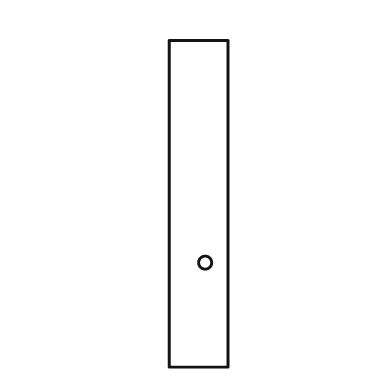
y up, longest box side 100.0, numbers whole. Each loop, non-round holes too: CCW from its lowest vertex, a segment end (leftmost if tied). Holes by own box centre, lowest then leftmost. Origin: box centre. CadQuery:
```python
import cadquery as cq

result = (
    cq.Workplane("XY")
    .moveTo(-9.0, -50.0)
    .lineTo(9.0, -50.0)
    .lineTo(9.0, 50.0)
    .lineTo(-9.0, 50.0)
    .close()
    .moveTo(2.0, -18.0)
    .circle(2.0)
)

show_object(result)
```